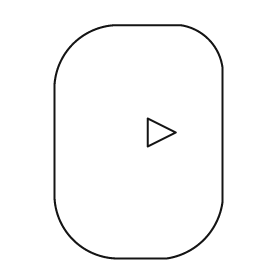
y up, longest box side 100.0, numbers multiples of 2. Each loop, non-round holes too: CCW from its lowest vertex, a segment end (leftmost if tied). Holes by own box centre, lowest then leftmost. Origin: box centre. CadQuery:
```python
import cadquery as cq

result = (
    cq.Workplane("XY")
    .moveTo(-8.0, -50.0)
    .lineTo(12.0, -50.0)
    .threePointArc((28.0, -42.0), (36.0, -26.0))
    .lineTo(36.0, 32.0)
    .threePointArc((30.0, 44.0), (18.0, 50.0))
    .lineTo(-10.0, 50.0)
    .threePointArc((-28.0, 42.0), (-36.0, 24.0))
    .lineTo(-36.0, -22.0)
    .threePointArc((-28.0, -42.0), (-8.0, -50.0))
    .close()
    .moveTo(4.0, -2.0)
    .lineTo(16.0, 4.0)
    .lineTo(4.0, 10.0)
    .close()
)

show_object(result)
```